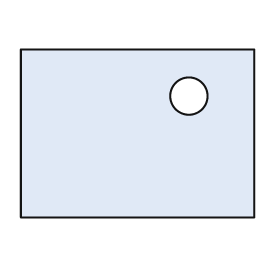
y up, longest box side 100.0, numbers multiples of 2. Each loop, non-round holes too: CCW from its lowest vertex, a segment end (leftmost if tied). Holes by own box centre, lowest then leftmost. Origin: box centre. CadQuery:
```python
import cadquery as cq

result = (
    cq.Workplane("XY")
    .moveTo(-50.0, -36.0)
    .lineTo(50.0, -36.0)
    .lineTo(50.0, 36.0)
    .lineTo(-50.0, 36.0)
    .close()
    .moveTo(22.0, 16.0)
    .circle(8.0)
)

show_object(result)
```